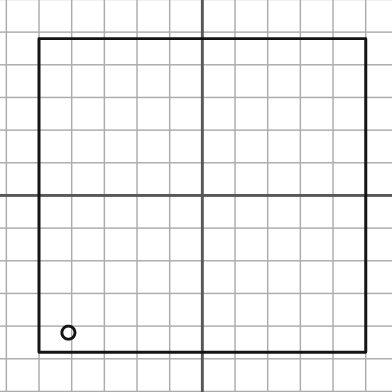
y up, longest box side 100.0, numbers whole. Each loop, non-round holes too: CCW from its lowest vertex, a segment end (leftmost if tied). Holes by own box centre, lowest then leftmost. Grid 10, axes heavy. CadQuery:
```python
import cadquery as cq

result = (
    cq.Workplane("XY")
    .moveTo(-50.0, -48.0)
    .lineTo(50.0, -48.0)
    .lineTo(50.0, 48.0)
    .lineTo(-50.0, 48.0)
    .close()
    .moveTo(-41.0, -42.0)
    .circle(2.0)
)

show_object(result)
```